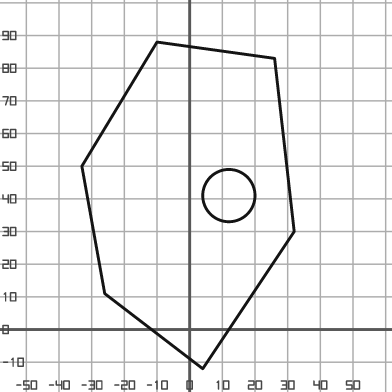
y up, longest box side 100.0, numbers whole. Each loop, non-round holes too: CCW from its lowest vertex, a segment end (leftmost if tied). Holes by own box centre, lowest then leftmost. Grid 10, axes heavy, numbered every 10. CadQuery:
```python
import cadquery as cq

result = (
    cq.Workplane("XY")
    .moveTo(4.0, -12.0)
    .lineTo(32.0, 30.0)
    .lineTo(26.0, 83.0)
    .lineTo(-10.0, 88.0)
    .lineTo(-33.0, 50.0)
    .lineTo(-26.0, 11.0)
    .close()
    .moveTo(12.0, 41.0)
    .circle(8.0)
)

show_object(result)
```